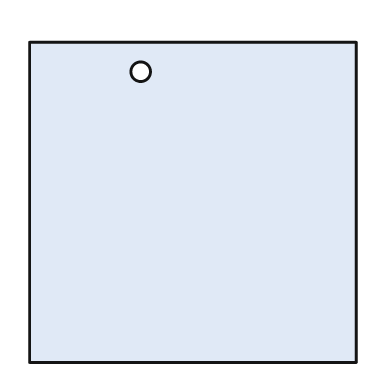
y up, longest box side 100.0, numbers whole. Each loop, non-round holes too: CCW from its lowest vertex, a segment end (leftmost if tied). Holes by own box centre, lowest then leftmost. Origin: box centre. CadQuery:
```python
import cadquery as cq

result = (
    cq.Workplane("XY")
    .moveTo(-50.0, -49.0)
    .lineTo(50.0, -49.0)
    .lineTo(50.0, 49.0)
    .lineTo(-50.0, 49.0)
    .close()
    .moveTo(-16.0, 40.0)
    .circle(3.0)
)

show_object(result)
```